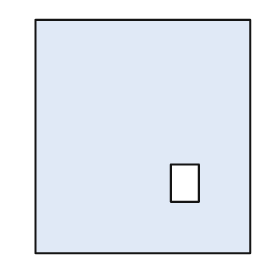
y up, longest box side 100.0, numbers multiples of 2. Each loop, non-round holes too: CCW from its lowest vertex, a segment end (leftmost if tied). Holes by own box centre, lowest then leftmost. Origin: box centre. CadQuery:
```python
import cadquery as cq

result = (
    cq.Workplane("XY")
    .moveTo(-46.0, -50.0)
    .lineTo(46.0, -50.0)
    .lineTo(46.0, 50.0)
    .lineTo(-46.0, 50.0)
    .close()
    .moveTo(12.0, -28.0)
    .lineTo(24.0, -28.0)
    .lineTo(24.0, -12.0)
    .lineTo(12.0, -12.0)
    .close()
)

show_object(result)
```